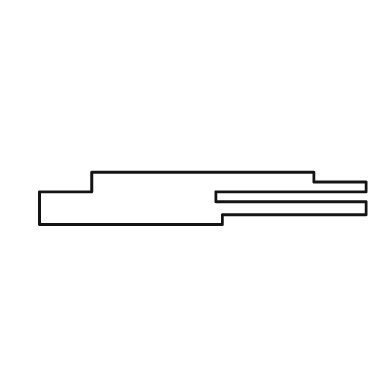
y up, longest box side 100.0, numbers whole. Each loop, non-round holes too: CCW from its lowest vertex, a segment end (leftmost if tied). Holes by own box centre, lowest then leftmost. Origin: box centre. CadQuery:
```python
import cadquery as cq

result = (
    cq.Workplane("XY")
    .moveTo(-50.0, -8.0)
    .lineTo(6.0, -8.0)
    .lineTo(6.0, -5.0)
    .lineTo(50.0, -5.0)
    .lineTo(50.0, -1.0)
    .lineTo(4.0, -1.0)
    .lineTo(4.0, 2.0)
    .lineTo(50.0, 2.0)
    .lineTo(50.0, 5.0)
    .lineTo(34.0, 5.0)
    .lineTo(34.0, 8.0)
    .lineTo(-34.0, 8.0)
    .lineTo(-34.0, 2.0)
    .lineTo(-50.0, 2.0)
    .close()
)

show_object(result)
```